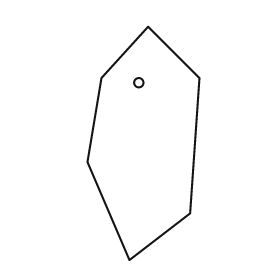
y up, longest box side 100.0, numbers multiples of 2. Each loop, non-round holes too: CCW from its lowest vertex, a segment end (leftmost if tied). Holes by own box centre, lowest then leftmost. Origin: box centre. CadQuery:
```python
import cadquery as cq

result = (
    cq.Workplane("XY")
    .moveTo(-6.0, -50.0)
    .lineTo(20.0, -30.0)
    .lineTo(24.0, 28.0)
    .lineTo(2.0, 50.0)
    .lineTo(-18.0, 28.0)
    .lineTo(-24.0, -8.0)
    .close()
    .moveTo(-2.0, 26.0)
    .circle(2.0)
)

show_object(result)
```